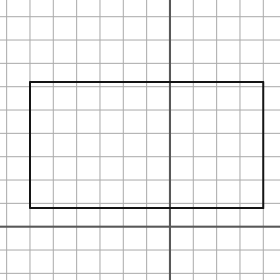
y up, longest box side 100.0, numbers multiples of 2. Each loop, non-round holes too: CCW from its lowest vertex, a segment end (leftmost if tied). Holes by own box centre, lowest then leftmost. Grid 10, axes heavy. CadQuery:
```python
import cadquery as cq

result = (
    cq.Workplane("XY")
    .moveTo(-60.0, 8.0)
    .lineTo(40.0, 8.0)
    .lineTo(40.0, 62.0)
    .lineTo(-60.0, 62.0)
    .close()
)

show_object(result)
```